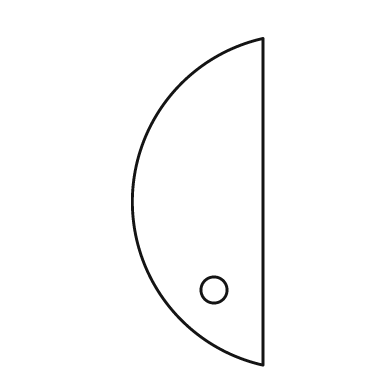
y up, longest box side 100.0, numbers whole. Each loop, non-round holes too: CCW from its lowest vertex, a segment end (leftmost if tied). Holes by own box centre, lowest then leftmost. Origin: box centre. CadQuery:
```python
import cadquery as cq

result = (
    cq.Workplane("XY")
    .moveTo(20.0, -50.0)
    .lineTo(20.0, 50.0)
    .threePointArc((-20.0, 0.0), (20.0, -50.0))
    .close()
    .moveTo(5.0, -27.0)
    .circle(4.0)
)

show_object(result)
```